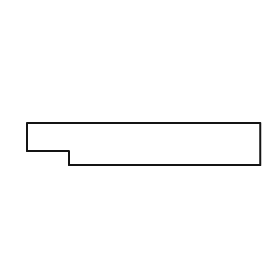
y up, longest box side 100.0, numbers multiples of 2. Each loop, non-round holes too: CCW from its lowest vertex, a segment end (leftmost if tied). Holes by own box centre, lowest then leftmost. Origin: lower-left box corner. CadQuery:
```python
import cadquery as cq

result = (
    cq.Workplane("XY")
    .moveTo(18.0, 0.0)
    .lineTo(100.0, 0.0)
    .lineTo(100.0, 18.0)
    .lineTo(0.0, 18.0)
    .lineTo(0.0, 6.0)
    .lineTo(18.0, 6.0)
    .close()
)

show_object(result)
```